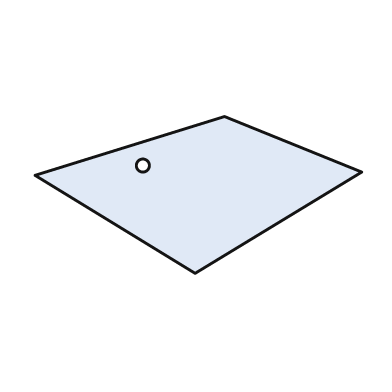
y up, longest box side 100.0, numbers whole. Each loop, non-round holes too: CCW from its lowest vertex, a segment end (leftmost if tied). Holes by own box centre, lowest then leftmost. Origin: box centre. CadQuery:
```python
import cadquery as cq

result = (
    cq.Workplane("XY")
    .moveTo(-1.0, -24.0)
    .lineTo(50.0, 7.0)
    .lineTo(8.0, 24.0)
    .lineTo(-50.0, 6.0)
    .close()
    .moveTo(-17.0, 9.0)
    .circle(2.0)
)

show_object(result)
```